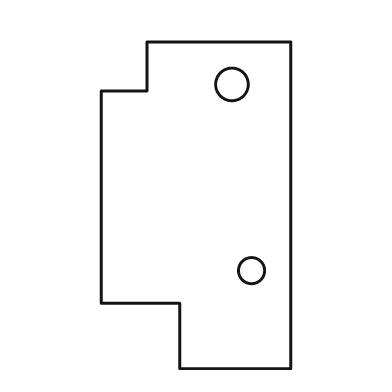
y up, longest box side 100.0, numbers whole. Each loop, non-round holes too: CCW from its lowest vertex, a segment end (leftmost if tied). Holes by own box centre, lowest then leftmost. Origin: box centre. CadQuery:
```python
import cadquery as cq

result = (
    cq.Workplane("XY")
    .moveTo(-5.0, -50.0)
    .lineTo(29.0, -50.0)
    .lineTo(29.0, 50.0)
    .lineTo(-15.0, 50.0)
    .lineTo(-15.0, 35.0)
    .lineTo(-29.0, 35.0)
    .lineTo(-29.0, -30.0)
    .lineTo(-5.0, -30.0)
    .close()
    .moveTo(17.0, -20.0)
    .circle(4.0)
    .moveTo(11.0, 37.0)
    .circle(5.0)
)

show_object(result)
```